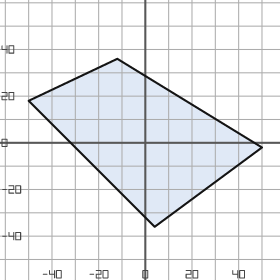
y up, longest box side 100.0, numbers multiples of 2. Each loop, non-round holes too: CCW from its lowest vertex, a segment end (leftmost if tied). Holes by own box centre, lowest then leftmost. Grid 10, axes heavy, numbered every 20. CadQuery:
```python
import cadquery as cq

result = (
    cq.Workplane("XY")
    .moveTo(4.0, -36.0)
    .lineTo(50.0, -2.0)
    .lineTo(-12.0, 36.0)
    .lineTo(-50.0, 18.0)
    .close()
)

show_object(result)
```